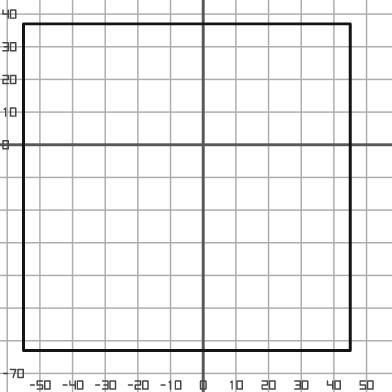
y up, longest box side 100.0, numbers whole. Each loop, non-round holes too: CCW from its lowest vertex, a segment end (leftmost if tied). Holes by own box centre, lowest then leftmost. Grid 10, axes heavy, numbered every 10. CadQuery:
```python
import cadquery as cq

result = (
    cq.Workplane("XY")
    .moveTo(-55.0, -63.0)
    .lineTo(45.0, -63.0)
    .lineTo(45.0, 37.0)
    .lineTo(-55.0, 37.0)
    .close()
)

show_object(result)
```